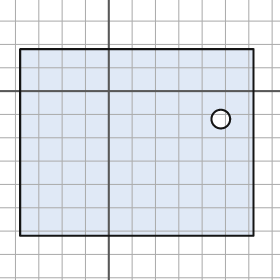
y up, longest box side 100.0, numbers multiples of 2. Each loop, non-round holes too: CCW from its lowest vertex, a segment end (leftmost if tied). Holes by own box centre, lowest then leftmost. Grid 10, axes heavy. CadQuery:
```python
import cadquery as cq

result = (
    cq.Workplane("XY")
    .moveTo(-38.0, -62.0)
    .lineTo(62.0, -62.0)
    .lineTo(62.0, 18.0)
    .lineTo(-38.0, 18.0)
    .close()
    .moveTo(48.0, -12.0)
    .circle(4.0)
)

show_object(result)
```